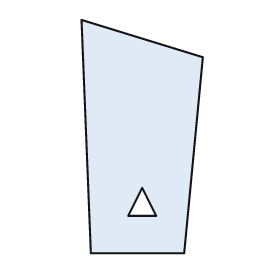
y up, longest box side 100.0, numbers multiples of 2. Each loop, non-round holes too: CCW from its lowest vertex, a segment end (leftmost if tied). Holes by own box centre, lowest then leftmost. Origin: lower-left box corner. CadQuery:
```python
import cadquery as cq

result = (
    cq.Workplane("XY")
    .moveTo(4.0, 0.0)
    .lineTo(44.0, 0.0)
    .lineTo(52.0, 84.0)
    .lineTo(0.0, 100.0)
    .close()
    .moveTo(20.0, 16.0)
    .lineTo(32.0, 16.0)
    .lineTo(26.0, 28.0)
    .close()
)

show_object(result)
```